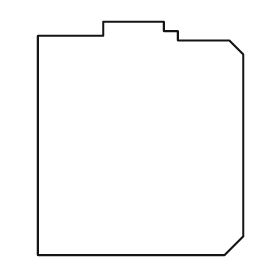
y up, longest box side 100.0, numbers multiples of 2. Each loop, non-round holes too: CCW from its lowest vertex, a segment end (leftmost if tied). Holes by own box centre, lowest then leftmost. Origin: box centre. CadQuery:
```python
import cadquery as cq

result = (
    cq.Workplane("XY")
    .moveTo(-44.0, -50.0)
    .lineTo(36.0, -50.0)
    .lineTo(44.0, -42.0)
    .lineTo(44.0, 36.0)
    .lineTo(38.0, 42.0)
    .lineTo(16.0, 42.0)
    .lineTo(16.0, 46.0)
    .lineTo(10.0, 46.0)
    .lineTo(10.0, 50.0)
    .lineTo(-16.0, 50.0)
    .lineTo(-16.0, 44.0)
    .lineTo(-44.0, 44.0)
    .close()
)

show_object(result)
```